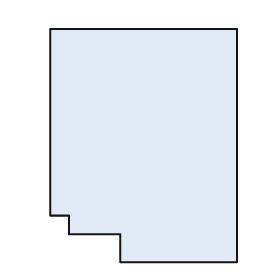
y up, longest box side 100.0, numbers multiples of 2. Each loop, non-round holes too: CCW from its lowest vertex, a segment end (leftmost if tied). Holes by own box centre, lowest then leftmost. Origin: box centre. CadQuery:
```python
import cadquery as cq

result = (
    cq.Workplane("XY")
    .moveTo(-10.0, -50.0)
    .lineTo(40.0, -50.0)
    .lineTo(40.0, 50.0)
    .lineTo(-40.0, 50.0)
    .lineTo(-40.0, -30.0)
    .lineTo(-32.0, -30.0)
    .lineTo(-32.0, -38.0)
    .lineTo(-10.0, -38.0)
    .close()
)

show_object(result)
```